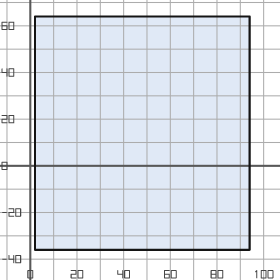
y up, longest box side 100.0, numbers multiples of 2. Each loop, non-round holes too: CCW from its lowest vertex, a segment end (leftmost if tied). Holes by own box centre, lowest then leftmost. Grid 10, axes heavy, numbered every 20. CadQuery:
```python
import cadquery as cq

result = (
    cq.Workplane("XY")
    .moveTo(2.0, -36.0)
    .lineTo(94.0, -36.0)
    .lineTo(94.0, 64.0)
    .lineTo(2.0, 64.0)
    .close()
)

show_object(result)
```